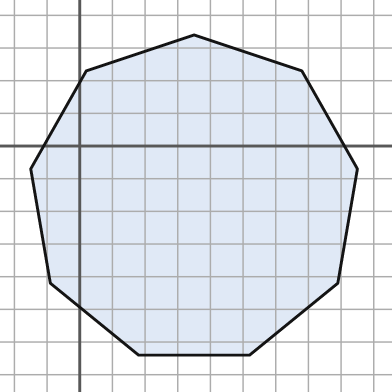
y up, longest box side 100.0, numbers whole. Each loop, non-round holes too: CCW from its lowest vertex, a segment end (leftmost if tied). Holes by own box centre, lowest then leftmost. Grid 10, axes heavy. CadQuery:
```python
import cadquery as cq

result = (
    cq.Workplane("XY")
    .moveTo(18.0, -64.0)
    .lineTo(52.0, -64.0)
    .lineTo(79.0, -42.0)
    .lineTo(85.0, -7.0)
    .lineTo(68.0, 23.0)
    .lineTo(35.0, 34.0)
    .lineTo(2.0, 23.0)
    .lineTo(-15.0, -7.0)
    .lineTo(-9.0, -42.0)
    .close()
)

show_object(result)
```